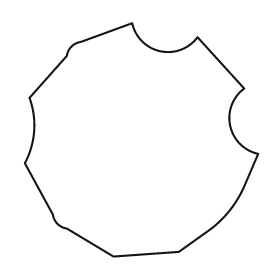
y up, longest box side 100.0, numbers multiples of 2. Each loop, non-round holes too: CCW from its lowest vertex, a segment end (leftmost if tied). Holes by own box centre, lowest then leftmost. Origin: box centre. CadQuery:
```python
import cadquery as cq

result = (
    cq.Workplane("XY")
    .moveTo(-12.0, -50.0)
    .lineTo(16.0, -48.0)
    .lineTo(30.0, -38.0)
    .threePointArc((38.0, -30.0), (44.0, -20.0))
    .lineTo(50.0, -6.0)
    .threePointArc((38.0, 6.0), (44.0, 22.0))
    .lineTo(24.0, 44.0)
    .threePointArc((8.0, 38.0), (-4.0, 50.0))
    .lineTo(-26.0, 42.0)
    .threePointArc((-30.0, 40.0), (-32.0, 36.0))
    .lineTo(-48.0, 18.0)
    .threePointArc((-46.0, 4.0), (-50.0, -10.0))
    .lineTo(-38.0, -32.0)
    .threePointArc((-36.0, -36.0), (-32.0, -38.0))
    .close()
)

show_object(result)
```